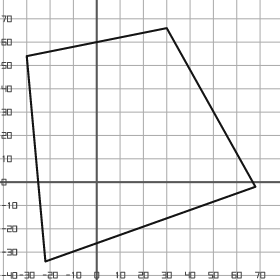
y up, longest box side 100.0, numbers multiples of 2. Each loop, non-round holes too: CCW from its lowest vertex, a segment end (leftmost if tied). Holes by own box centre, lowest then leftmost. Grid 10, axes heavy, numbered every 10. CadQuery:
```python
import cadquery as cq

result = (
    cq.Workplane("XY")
    .moveTo(-22.0, -34.0)
    .lineTo(68.0, -2.0)
    .lineTo(30.0, 66.0)
    .lineTo(-30.0, 54.0)
    .close()
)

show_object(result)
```